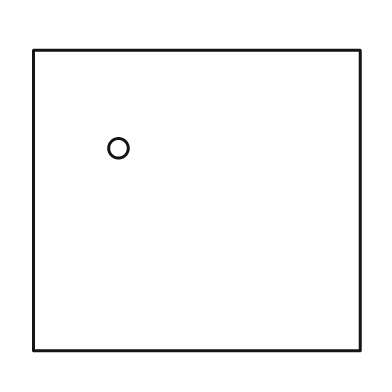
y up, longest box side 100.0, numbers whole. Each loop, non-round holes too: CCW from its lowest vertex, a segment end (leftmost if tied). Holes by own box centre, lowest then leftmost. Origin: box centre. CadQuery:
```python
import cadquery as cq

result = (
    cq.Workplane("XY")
    .moveTo(-50.0, -46.0)
    .lineTo(50.0, -46.0)
    .lineTo(50.0, 46.0)
    .lineTo(-50.0, 46.0)
    .close()
    .moveTo(-24.0, 16.0)
    .circle(3.0)
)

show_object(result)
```